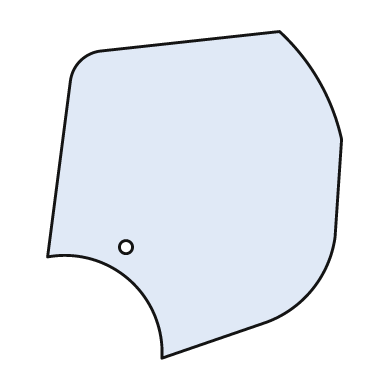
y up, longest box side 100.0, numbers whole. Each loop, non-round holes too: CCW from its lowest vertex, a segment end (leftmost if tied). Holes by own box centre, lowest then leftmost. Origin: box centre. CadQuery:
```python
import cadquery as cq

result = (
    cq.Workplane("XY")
    .moveTo(-10.0, -50.0)
    .lineTo(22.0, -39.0)
    .threePointArc((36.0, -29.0), (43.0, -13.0))
    .lineTo(45.0, 17.0)
    .threePointArc((38.0, 35.0), (26.0, 50.0))
    .lineTo(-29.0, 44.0)
    .threePointArc((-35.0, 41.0), (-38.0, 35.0))
    .lineTo(-45.0, -19.0)
    .threePointArc((-20.0, -26.0), (-10.0, -50.0))
    .close()
    .moveTo(-21.0, -16.0)
    .circle(2.0)
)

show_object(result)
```